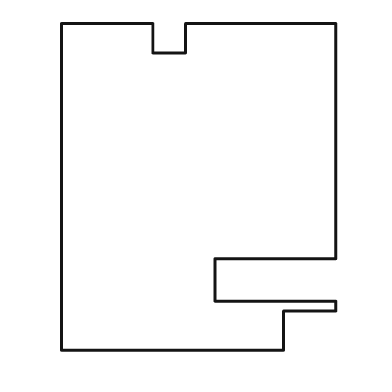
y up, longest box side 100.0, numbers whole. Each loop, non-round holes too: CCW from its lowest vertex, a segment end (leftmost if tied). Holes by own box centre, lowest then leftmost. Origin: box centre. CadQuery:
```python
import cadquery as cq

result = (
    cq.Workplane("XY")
    .moveTo(-42.0, -50.0)
    .lineTo(26.0, -50.0)
    .lineTo(26.0, -38.0)
    .lineTo(42.0, -38.0)
    .lineTo(42.0, -35.0)
    .lineTo(5.0, -35.0)
    .lineTo(5.0, -22.0)
    .lineTo(42.0, -22.0)
    .lineTo(42.0, 50.0)
    .lineTo(-4.0, 50.0)
    .lineTo(-4.0, 41.0)
    .lineTo(-14.0, 41.0)
    .lineTo(-14.0, 50.0)
    .lineTo(-42.0, 50.0)
    .close()
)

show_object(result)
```